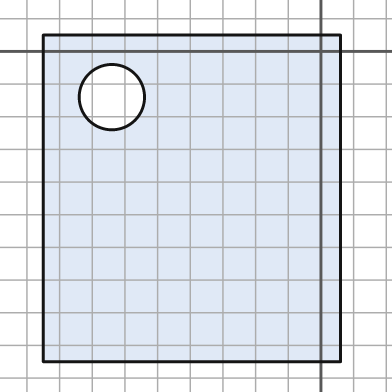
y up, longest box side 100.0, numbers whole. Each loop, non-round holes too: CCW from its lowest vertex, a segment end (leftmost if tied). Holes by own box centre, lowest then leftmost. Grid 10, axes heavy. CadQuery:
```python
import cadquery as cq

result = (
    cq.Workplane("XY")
    .moveTo(-85.0, -95.0)
    .lineTo(6.0, -95.0)
    .lineTo(6.0, 5.0)
    .lineTo(-85.0, 5.0)
    .close()
    .moveTo(-64.0, -14.0)
    .circle(10.0)
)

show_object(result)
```